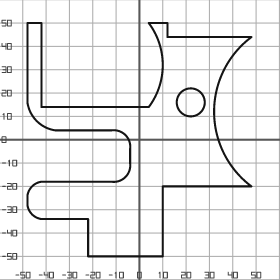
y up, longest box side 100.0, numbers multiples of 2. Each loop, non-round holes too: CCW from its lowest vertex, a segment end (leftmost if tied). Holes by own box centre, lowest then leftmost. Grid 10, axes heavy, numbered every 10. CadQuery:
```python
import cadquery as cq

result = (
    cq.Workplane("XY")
    .moveTo(-22.0, -50.0)
    .lineTo(10.0, -50.0)
    .lineTo(10.0, -20.0)
    .lineTo(48.0, -20.0)
    .threePointArc((32.0, 12.0), (48.0, 44.0))
    .lineTo(12.0, 44.0)
    .lineTo(12.0, 50.0)
    .lineTo(4.0, 50.0)
    .threePointArc((10.0, 32.0), (4.0, 14.0))
    .lineTo(-42.0, 14.0)
    .lineTo(-42.0, 50.0)
    .lineTo(-48.0, 50.0)
    .lineTo(-48.0, 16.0)
    .threePointArc((-44.0, 8.0), (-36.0, 4.0))
    .lineTo(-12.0, 4.0)
    .threePointArc((-6.0, 2.0), (-4.0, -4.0))
    .lineTo(-4.0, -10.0)
    .threePointArc((-6.0, -16.0), (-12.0, -18.0))
    .lineTo(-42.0, -18.0)
    .threePointArc((-46.0, -20.0), (-48.0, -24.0))
    .lineTo(-48.0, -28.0)
    .threePointArc((-46.0, -32.0), (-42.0, -34.0))
    .lineTo(-22.0, -34.0)
    .close()
    .moveTo(22.0, 16.0)
    .circle(6.0)
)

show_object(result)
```